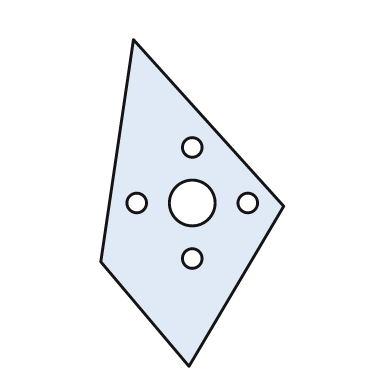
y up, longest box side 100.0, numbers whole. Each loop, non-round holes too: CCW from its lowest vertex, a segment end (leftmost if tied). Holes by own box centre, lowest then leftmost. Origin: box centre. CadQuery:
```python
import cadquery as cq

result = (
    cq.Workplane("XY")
    .moveTo(-1.0, -50.0)
    .lineTo(28.0, -1.0)
    .lineTo(-18.0, 50.0)
    .lineTo(-28.0, -18.0)
    .close()
    .moveTo(0.0, -17.0)
    .circle(3.0)
    .moveTo(-17.0, 0.0)
    .circle(3.0)
    .moveTo(0.0, 0.0)
    .circle(7.0)
    .moveTo(17.0, 0.0)
    .circle(3.0)
    .moveTo(0.0, 17.0)
    .circle(3.0)
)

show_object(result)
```